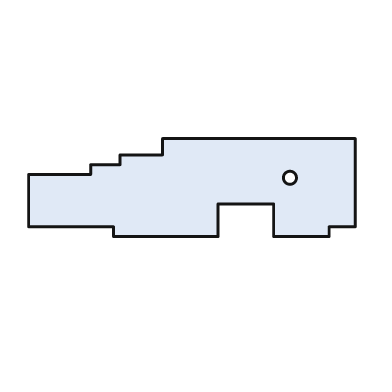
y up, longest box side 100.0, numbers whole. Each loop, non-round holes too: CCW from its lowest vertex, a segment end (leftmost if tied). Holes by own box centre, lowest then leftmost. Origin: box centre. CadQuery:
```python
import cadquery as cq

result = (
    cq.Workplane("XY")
    .moveTo(-24.0, -15.0)
    .lineTo(8.0, -15.0)
    .lineTo(8.0, -5.0)
    .lineTo(25.0, -5.0)
    .lineTo(25.0, -15.0)
    .lineTo(42.0, -15.0)
    .lineTo(42.0, -12.0)
    .lineTo(50.0, -12.0)
    .lineTo(50.0, 15.0)
    .lineTo(-9.0, 15.0)
    .lineTo(-9.0, 10.0)
    .lineTo(-22.0, 10.0)
    .lineTo(-22.0, 7.0)
    .lineTo(-31.0, 7.0)
    .lineTo(-31.0, 4.0)
    .lineTo(-50.0, 4.0)
    .lineTo(-50.0, -12.0)
    .lineTo(-24.0, -12.0)
    .close()
    .moveTo(30.0, 3.0)
    .circle(2.0)
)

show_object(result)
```